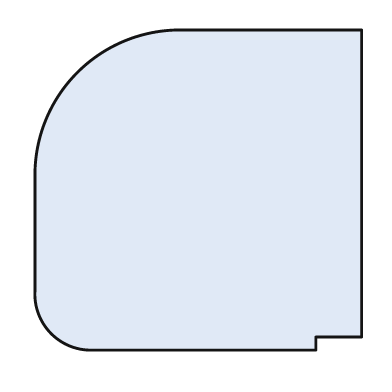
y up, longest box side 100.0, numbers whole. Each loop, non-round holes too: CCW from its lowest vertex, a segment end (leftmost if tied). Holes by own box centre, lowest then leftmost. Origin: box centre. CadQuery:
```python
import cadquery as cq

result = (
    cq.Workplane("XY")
    .moveTo(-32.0, -49.0)
    .lineTo(36.0, -49.0)
    .lineTo(36.0, -45.0)
    .lineTo(50.0, -45.0)
    .lineTo(50.0, 49.0)
    .lineTo(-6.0, 49.0)
    .threePointArc((-37.0, 36.0), (-50.0, 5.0))
    .lineTo(-50.0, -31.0)
    .threePointArc((-45.0, -44.0), (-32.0, -49.0))
    .close()
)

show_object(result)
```